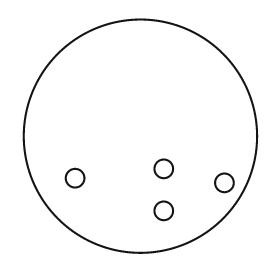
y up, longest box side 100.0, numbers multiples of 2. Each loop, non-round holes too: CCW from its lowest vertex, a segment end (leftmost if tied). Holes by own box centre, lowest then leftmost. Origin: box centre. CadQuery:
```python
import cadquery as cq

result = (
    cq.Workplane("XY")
    .moveTo(0.0, 0.0)
    .circle(50.0)
    .moveTo(10.0, -32.0)
    .circle(4.0)
    .moveTo(36.0, -20.0)
    .circle(4.0)
    .moveTo(-28.0, -18.0)
    .circle(4.0)
    .moveTo(10.0, -14.0)
    .circle(4.0)
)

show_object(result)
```